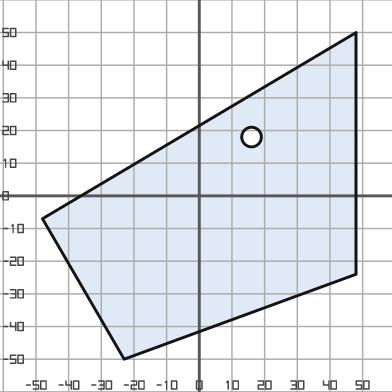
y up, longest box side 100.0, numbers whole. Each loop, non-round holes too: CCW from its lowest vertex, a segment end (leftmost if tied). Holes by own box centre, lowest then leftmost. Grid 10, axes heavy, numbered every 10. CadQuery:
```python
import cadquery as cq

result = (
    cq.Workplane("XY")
    .moveTo(-23.0, -50.0)
    .lineTo(48.0, -24.0)
    .lineTo(48.0, 50.0)
    .lineTo(-48.0, -7.0)
    .close()
    .moveTo(16.0, 18.0)
    .circle(3.0)
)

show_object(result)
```